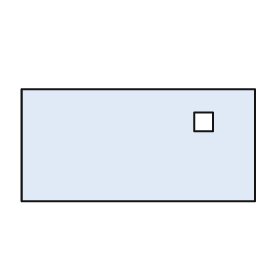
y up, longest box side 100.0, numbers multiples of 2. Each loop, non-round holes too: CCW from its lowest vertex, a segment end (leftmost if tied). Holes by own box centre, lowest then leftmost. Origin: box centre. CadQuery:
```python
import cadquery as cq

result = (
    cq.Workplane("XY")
    .moveTo(-50.0, -24.0)
    .lineTo(50.0, -24.0)
    .lineTo(50.0, 24.0)
    .lineTo(-50.0, 24.0)
    .close()
    .moveTo(24.0, 6.0)
    .lineTo(32.0, 6.0)
    .lineTo(32.0, 14.0)
    .lineTo(24.0, 14.0)
    .close()
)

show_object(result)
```